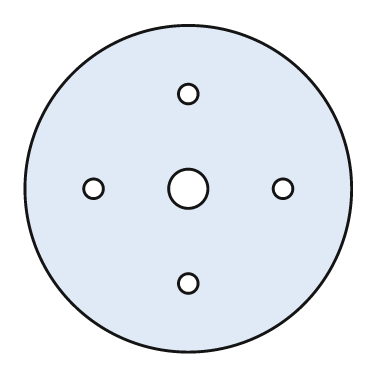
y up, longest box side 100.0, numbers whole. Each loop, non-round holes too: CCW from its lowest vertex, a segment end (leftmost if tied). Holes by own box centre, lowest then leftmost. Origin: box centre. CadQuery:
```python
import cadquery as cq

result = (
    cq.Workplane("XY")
    .moveTo(0.0, 0.0)
    .circle(50.0)
    .moveTo(0.0, -29.0)
    .circle(3.0)
    .moveTo(-29.0, 0.0)
    .circle(3.0)
    .moveTo(0.0, 0.0)
    .circle(6.0)
    .moveTo(29.0, 0.0)
    .circle(3.0)
    .moveTo(0.0, 29.0)
    .circle(3.0)
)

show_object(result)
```